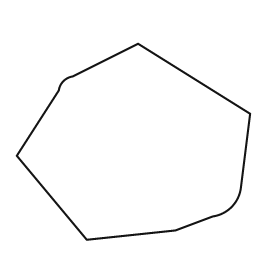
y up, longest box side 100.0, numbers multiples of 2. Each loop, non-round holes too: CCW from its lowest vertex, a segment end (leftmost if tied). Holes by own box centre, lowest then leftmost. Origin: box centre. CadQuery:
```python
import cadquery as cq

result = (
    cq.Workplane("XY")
    .moveTo(-20.0, -42.0)
    .lineTo(18.0, -38.0)
    .lineTo(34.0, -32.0)
    .threePointArc((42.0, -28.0), (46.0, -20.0))
    .lineTo(50.0, 12.0)
    .lineTo(2.0, 42.0)
    .lineTo(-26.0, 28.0)
    .threePointArc((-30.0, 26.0), (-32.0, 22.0))
    .lineTo(-50.0, -6.0)
    .close()
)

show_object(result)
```